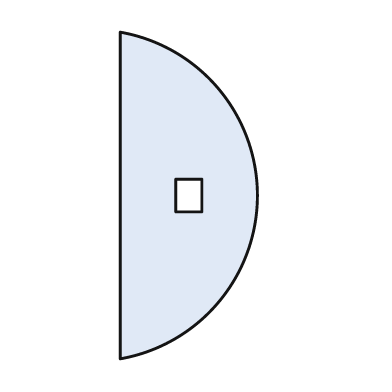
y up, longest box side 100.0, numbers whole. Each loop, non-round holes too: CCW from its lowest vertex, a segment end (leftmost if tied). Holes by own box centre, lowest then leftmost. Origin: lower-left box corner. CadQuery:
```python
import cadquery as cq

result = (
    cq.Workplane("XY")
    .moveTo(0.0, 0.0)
    .threePointArc((42.0, 50.0), (0.0, 100.0))
    .close()
    .moveTo(17.0, 45.0)
    .lineTo(25.0, 45.0)
    .lineTo(25.0, 55.0)
    .lineTo(17.0, 55.0)
    .close()
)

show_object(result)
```